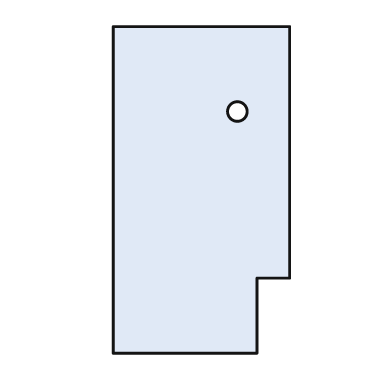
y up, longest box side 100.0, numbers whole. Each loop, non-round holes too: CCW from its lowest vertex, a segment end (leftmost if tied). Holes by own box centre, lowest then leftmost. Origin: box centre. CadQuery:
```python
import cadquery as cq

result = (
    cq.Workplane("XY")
    .moveTo(-27.0, -50.0)
    .lineTo(17.0, -50.0)
    .lineTo(17.0, -27.0)
    .lineTo(27.0, -27.0)
    .lineTo(27.0, 50.0)
    .lineTo(-27.0, 50.0)
    .close()
    .moveTo(11.0, 24.0)
    .circle(3.0)
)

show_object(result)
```